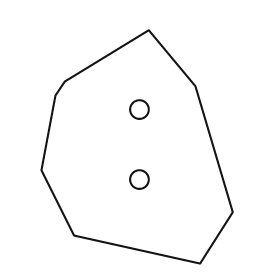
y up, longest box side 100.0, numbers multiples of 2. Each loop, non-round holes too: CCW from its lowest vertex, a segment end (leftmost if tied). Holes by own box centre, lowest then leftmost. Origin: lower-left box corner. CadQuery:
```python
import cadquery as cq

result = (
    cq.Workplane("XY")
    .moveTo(68.0, 0.0)
    .lineTo(82.0, 22.0)
    .lineTo(66.0, 76.0)
    .lineTo(46.0, 100.0)
    .lineTo(10.0, 78.0)
    .lineTo(6.0, 72.0)
    .lineTo(0.0, 40.0)
    .lineTo(14.0, 12.0)
    .close()
    .moveTo(42.0, 36.0)
    .circle(4.0)
    .moveTo(42.0, 66.0)
    .circle(4.0)
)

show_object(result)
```